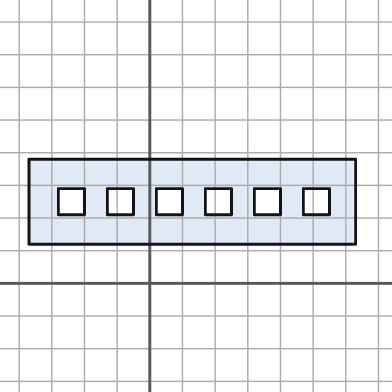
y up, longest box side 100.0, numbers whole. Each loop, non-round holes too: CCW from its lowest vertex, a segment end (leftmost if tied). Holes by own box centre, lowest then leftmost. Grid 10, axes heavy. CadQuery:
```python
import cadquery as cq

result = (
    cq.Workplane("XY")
    .moveTo(-37.0, 12.0)
    .lineTo(63.0, 12.0)
    .lineTo(63.0, 38.0)
    .lineTo(-37.0, 38.0)
    .close()
    .moveTo(-28.0, 21.0)
    .lineTo(-20.0, 21.0)
    .lineTo(-20.0, 29.0)
    .lineTo(-28.0, 29.0)
    .close()
    .moveTo(-13.0, 21.0)
    .lineTo(-5.0, 21.0)
    .lineTo(-5.0, 29.0)
    .lineTo(-13.0, 29.0)
    .close()
    .moveTo(2.0, 21.0)
    .lineTo(10.0, 21.0)
    .lineTo(10.0, 29.0)
    .lineTo(2.0, 29.0)
    .close()
    .moveTo(17.0, 21.0)
    .lineTo(25.0, 21.0)
    .lineTo(25.0, 29.0)
    .lineTo(17.0, 29.0)
    .close()
    .moveTo(32.0, 21.0)
    .lineTo(40.0, 21.0)
    .lineTo(40.0, 29.0)
    .lineTo(32.0, 29.0)
    .close()
    .moveTo(47.0, 21.0)
    .lineTo(55.0, 21.0)
    .lineTo(55.0, 29.0)
    .lineTo(47.0, 29.0)
    .close()
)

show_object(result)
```